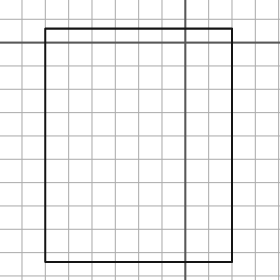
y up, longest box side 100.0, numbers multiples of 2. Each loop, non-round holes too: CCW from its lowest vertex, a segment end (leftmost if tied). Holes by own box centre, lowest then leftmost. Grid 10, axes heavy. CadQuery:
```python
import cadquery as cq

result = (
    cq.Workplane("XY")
    .moveTo(-60.0, -94.0)
    .lineTo(20.0, -94.0)
    .lineTo(20.0, 6.0)
    .lineTo(-60.0, 6.0)
    .close()
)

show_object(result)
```